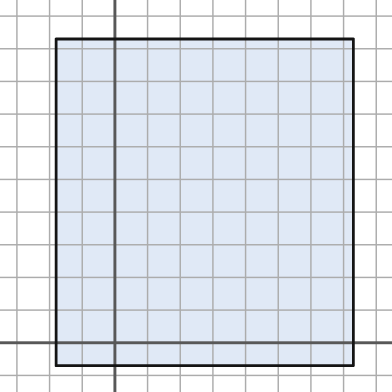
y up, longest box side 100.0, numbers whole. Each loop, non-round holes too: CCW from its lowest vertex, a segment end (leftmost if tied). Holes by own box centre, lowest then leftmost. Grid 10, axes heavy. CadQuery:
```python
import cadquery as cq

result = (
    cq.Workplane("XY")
    .moveTo(-18.0, -7.0)
    .lineTo(73.0, -7.0)
    .lineTo(73.0, 93.0)
    .lineTo(-18.0, 93.0)
    .close()
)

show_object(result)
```